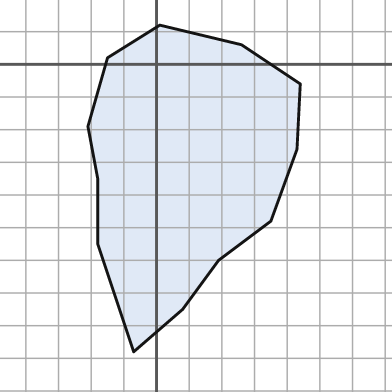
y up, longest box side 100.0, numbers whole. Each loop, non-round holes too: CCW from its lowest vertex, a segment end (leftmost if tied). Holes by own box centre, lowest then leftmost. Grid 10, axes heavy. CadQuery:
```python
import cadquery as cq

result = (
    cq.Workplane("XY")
    .moveTo(-7.0, -88.0)
    .lineTo(8.0, -75.0)
    .lineTo(19.0, -60.0)
    .lineTo(35.0, -48.0)
    .lineTo(43.0, -26.0)
    .lineTo(44.0, -6.0)
    .lineTo(26.0, 6.0)
    .lineTo(1.0, 12.0)
    .lineTo(-15.0, 2.0)
    .lineTo(-21.0, -19.0)
    .lineTo(-18.0, -35.0)
    .lineTo(-18.0, -55.0)
    .close()
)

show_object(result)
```